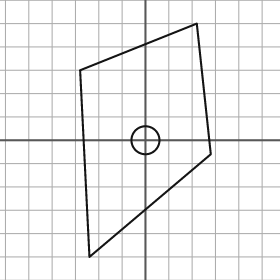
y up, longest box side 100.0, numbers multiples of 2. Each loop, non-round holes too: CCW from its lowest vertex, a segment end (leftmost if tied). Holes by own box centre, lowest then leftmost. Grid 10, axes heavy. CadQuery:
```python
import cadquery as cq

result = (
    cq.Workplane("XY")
    .moveTo(-24.0, -50.0)
    .lineTo(28.0, -6.0)
    .lineTo(22.0, 50.0)
    .lineTo(-28.0, 30.0)
    .close()
    .moveTo(0.0, 0.0)
    .circle(6.0)
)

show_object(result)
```